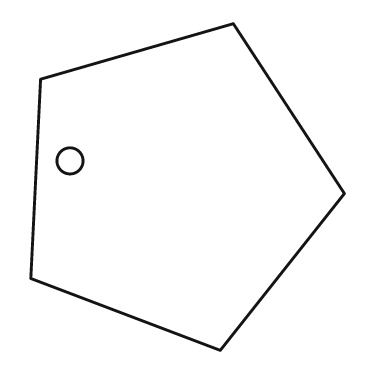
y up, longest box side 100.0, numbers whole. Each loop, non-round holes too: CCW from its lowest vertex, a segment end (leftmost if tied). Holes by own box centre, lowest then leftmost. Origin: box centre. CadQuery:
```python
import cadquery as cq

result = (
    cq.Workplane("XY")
    .moveTo(10.0, -50.0)
    .lineTo(48.0, -2.0)
    .lineTo(14.0, 50.0)
    .lineTo(-45.0, 33.0)
    .lineTo(-48.0, -28.0)
    .close()
    .moveTo(-36.0, 8.0)
    .circle(4.0)
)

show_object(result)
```